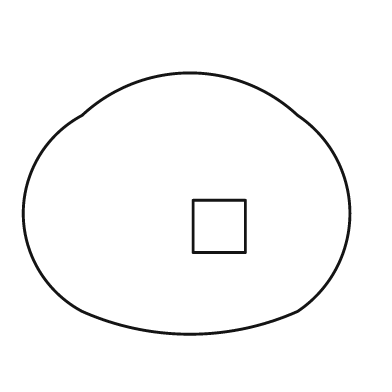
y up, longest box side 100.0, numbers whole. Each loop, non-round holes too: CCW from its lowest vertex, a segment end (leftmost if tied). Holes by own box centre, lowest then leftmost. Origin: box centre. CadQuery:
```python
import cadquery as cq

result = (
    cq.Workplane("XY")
    .moveTo(-32.0, -33.0)
    .threePointArc((1.0, -40.0), (34.0, -33.0))
    .threePointArc((50.0, -3.0), (34.0, 27.0))
    .threePointArc((1.0, 40.0), (-32.0, 27.0))
    .threePointArc((-50.0, -3.0), (-32.0, -33.0))
    .close()
    .moveTo(2.0, -15.0)
    .lineTo(18.0, -15.0)
    .lineTo(18.0, 1.0)
    .lineTo(2.0, 1.0)
    .close()
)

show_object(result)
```